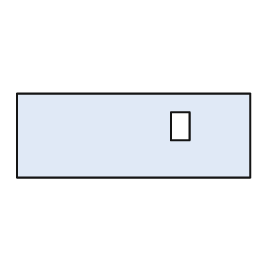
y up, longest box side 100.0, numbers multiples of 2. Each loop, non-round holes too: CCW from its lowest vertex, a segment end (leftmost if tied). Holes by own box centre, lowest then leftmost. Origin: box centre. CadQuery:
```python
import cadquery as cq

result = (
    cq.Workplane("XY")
    .moveTo(-50.0, -18.0)
    .lineTo(50.0, -18.0)
    .lineTo(50.0, 18.0)
    .lineTo(-50.0, 18.0)
    .close()
    .moveTo(16.0, -2.0)
    .lineTo(24.0, -2.0)
    .lineTo(24.0, 10.0)
    .lineTo(16.0, 10.0)
    .close()
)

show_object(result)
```